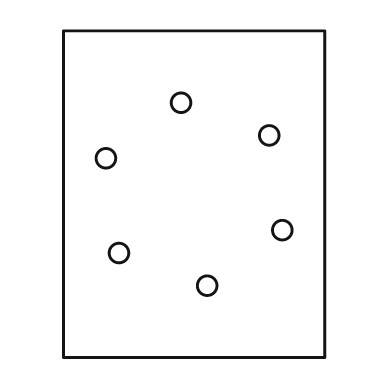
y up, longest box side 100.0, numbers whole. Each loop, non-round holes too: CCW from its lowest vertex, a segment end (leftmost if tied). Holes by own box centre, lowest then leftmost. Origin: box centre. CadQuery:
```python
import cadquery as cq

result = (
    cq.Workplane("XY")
    .moveTo(-40.0, -50.0)
    .lineTo(40.0, -50.0)
    .lineTo(40.0, 50.0)
    .lineTo(-40.0, 50.0)
    .close()
    .moveTo(4.0, -28.0)
    .circle(3.0)
    .moveTo(-23.0, -18.0)
    .circle(3.0)
    .moveTo(27.0, -11.0)
    .circle(3.0)
    .moveTo(-27.0, 11.0)
    .circle(3.0)
    .moveTo(23.0, 18.0)
    .circle(3.0)
    .moveTo(-4.0, 28.0)
    .circle(3.0)
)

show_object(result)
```